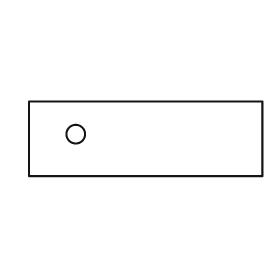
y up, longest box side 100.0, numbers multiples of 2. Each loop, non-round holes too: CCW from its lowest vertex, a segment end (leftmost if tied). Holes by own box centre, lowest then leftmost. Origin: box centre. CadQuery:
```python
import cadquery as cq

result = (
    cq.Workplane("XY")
    .moveTo(-50.0, -16.0)
    .lineTo(50.0, -16.0)
    .lineTo(50.0, 16.0)
    .lineTo(-50.0, 16.0)
    .close()
    .moveTo(-30.0, 2.0)
    .circle(4.0)
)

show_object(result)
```